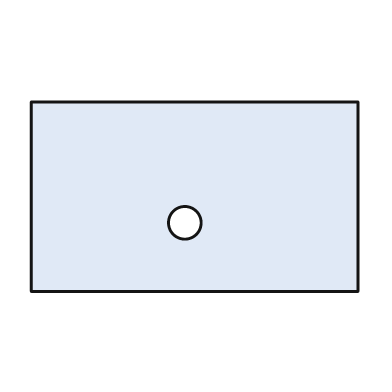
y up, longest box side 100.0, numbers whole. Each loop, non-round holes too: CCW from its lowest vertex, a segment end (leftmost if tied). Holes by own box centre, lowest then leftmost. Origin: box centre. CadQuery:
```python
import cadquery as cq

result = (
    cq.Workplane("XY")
    .moveTo(-50.0, -29.0)
    .lineTo(50.0, -29.0)
    .lineTo(50.0, 29.0)
    .lineTo(-50.0, 29.0)
    .close()
    .moveTo(-3.0, -8.0)
    .circle(5.0)
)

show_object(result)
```